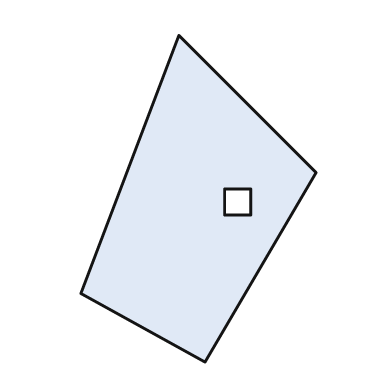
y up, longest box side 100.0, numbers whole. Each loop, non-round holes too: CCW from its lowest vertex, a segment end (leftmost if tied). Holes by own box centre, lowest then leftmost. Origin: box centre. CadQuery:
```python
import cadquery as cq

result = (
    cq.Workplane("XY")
    .moveTo(2.0, -50.0)
    .lineTo(36.0, 8.0)
    .lineTo(-6.0, 50.0)
    .lineTo(-36.0, -29.0)
    .close()
    .moveTo(8.0, -5.0)
    .lineTo(16.0, -5.0)
    .lineTo(16.0, 3.0)
    .lineTo(8.0, 3.0)
    .close()
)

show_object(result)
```